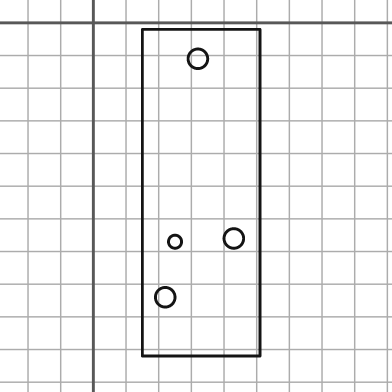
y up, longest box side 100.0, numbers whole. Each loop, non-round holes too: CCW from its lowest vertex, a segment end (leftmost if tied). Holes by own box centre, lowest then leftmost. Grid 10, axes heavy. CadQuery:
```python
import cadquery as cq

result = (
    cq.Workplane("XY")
    .moveTo(15.0, -102.0)
    .lineTo(51.0, -102.0)
    .lineTo(51.0, -2.0)
    .lineTo(15.0, -2.0)
    .close()
    .moveTo(22.0, -84.0)
    .circle(3.0)
    .moveTo(25.0, -67.0)
    .circle(2.0)
    .moveTo(43.0, -66.0)
    .circle(3.0)
    .moveTo(32.0, -11.0)
    .circle(3.0)
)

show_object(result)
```